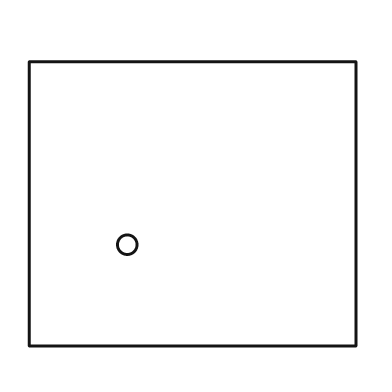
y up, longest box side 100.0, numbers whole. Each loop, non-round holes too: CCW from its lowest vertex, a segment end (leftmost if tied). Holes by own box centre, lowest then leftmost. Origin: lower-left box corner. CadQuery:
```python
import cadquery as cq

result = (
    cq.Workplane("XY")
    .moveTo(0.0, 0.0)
    .lineTo(100.0, 0.0)
    .lineTo(100.0, 87.0)
    .lineTo(0.0, 87.0)
    .close()
    .moveTo(30.0, 31.0)
    .circle(3.0)
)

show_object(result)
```